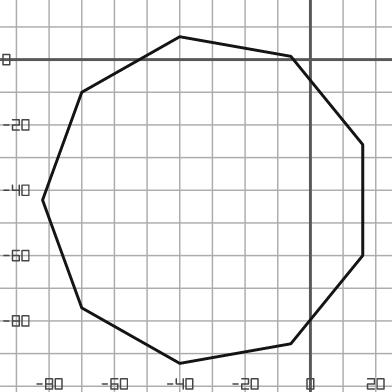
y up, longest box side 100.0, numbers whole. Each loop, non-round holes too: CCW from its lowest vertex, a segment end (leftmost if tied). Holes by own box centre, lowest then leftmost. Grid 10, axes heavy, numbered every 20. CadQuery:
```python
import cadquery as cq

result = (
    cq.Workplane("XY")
    .moveTo(-40.0, -93.0)
    .lineTo(-6.0, -87.0)
    .lineTo(16.0, -60.0)
    .lineTo(16.0, -26.0)
    .lineTo(-6.0, 1.0)
    .lineTo(-40.0, 7.0)
    .lineTo(-70.0, -10.0)
    .lineTo(-82.0, -43.0)
    .lineTo(-70.0, -76.0)
    .close()
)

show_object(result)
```